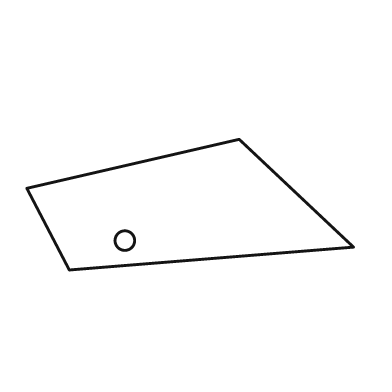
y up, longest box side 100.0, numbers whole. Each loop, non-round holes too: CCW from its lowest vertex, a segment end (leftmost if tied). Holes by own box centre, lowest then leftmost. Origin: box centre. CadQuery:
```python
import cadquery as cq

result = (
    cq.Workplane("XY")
    .moveTo(-37.0, -20.0)
    .lineTo(50.0, -13.0)
    .lineTo(15.0, 20.0)
    .lineTo(-50.0, 5.0)
    .close()
    .moveTo(-20.0, -11.0)
    .circle(3.0)
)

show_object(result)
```